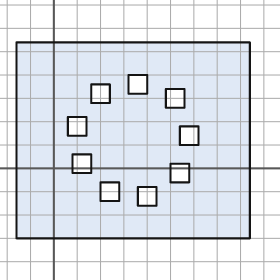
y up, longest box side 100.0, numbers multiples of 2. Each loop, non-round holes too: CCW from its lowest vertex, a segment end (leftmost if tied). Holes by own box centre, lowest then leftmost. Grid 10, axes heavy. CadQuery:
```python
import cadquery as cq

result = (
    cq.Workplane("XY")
    .moveTo(-16.0, -30.0)
    .lineTo(84.0, -30.0)
    .lineTo(84.0, 54.0)
    .lineTo(-16.0, 54.0)
    .close()
    .moveTo(36.0, -16.0)
    .lineTo(44.0, -16.0)
    .lineTo(44.0, -8.0)
    .lineTo(36.0, -8.0)
    .close()
    .moveTo(20.0, -14.0)
    .lineTo(28.0, -14.0)
    .lineTo(28.0, -6.0)
    .lineTo(20.0, -6.0)
    .close()
    .moveTo(50.0, -6.0)
    .lineTo(58.0, -6.0)
    .lineTo(58.0, 2.0)
    .lineTo(50.0, 2.0)
    .close()
    .moveTo(8.0, -2.0)
    .lineTo(16.0, -2.0)
    .lineTo(16.0, 6.0)
    .lineTo(8.0, 6.0)
    .close()
    .moveTo(54.0, 10.0)
    .lineTo(62.0, 10.0)
    .lineTo(62.0, 18.0)
    .lineTo(54.0, 18.0)
    .close()
    .moveTo(6.0, 14.0)
    .lineTo(14.0, 14.0)
    .lineTo(14.0, 22.0)
    .lineTo(6.0, 22.0)
    .close()
    .moveTo(48.0, 26.0)
    .lineTo(56.0, 26.0)
    .lineTo(56.0, 34.0)
    .lineTo(48.0, 34.0)
    .close()
    .moveTo(16.0, 28.0)
    .lineTo(24.0, 28.0)
    .lineTo(24.0, 36.0)
    .lineTo(16.0, 36.0)
    .close()
    .moveTo(32.0, 32.0)
    .lineTo(40.0, 32.0)
    .lineTo(40.0, 40.0)
    .lineTo(32.0, 40.0)
    .close()
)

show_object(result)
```